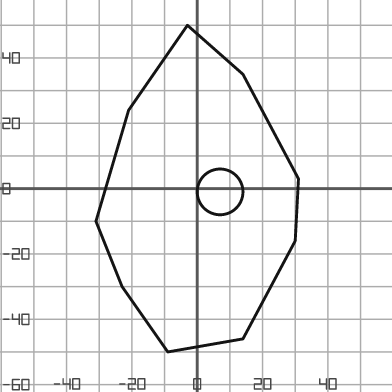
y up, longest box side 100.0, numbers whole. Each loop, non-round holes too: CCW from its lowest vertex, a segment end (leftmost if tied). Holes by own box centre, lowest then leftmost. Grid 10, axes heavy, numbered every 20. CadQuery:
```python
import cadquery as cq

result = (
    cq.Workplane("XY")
    .moveTo(-9.0, -50.0)
    .lineTo(14.0, -46.0)
    .lineTo(30.0, -16.0)
    .lineTo(31.0, 3.0)
    .lineTo(14.0, 35.0)
    .lineTo(-3.0, 50.0)
    .lineTo(-21.0, 24.0)
    .lineTo(-31.0, -10.0)
    .lineTo(-23.0, -30.0)
    .close()
    .moveTo(7.0, -1.0)
    .circle(7.0)
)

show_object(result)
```